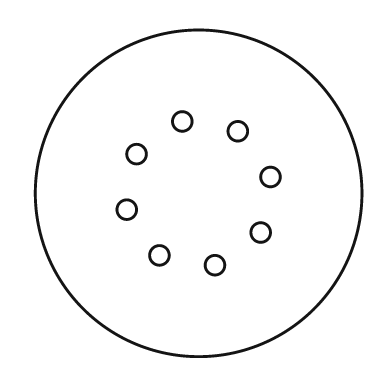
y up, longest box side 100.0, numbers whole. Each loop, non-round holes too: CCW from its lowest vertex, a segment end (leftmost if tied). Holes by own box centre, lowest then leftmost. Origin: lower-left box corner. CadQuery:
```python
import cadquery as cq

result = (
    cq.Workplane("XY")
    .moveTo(50.0, 50.0)
    .circle(50.0)
    .moveTo(55.0, 28.0)
    .circle(3.0)
    .moveTo(38.0, 31.0)
    .circle(3.0)
    .moveTo(69.0, 38.0)
    .circle(3.0)
    .moveTo(28.0, 45.0)
    .circle(3.0)
    .moveTo(72.0, 55.0)
    .circle(3.0)
    .moveTo(31.0, 62.0)
    .circle(3.0)
    .moveTo(62.0, 69.0)
    .circle(3.0)
    .moveTo(45.0, 72.0)
    .circle(3.0)
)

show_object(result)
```